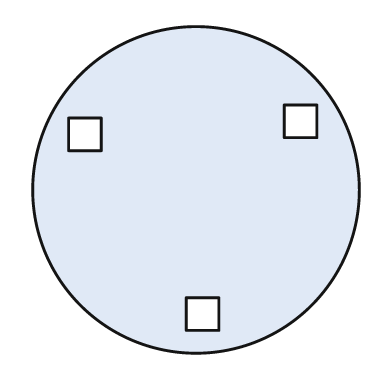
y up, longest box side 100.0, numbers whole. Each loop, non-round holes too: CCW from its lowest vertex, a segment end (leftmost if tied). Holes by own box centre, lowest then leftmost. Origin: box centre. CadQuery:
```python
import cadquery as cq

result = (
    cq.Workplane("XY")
    .moveTo(0.0, 0.0)
    .circle(50.0)
    .moveTo(-3.0, -43.0)
    .lineTo(7.0, -43.0)
    .lineTo(7.0, -33.0)
    .lineTo(-3.0, -33.0)
    .close()
    .moveTo(-39.0, 12.0)
    .lineTo(-29.0, 12.0)
    .lineTo(-29.0, 22.0)
    .lineTo(-39.0, 22.0)
    .close()
    .moveTo(27.0, 16.0)
    .lineTo(37.0, 16.0)
    .lineTo(37.0, 26.0)
    .lineTo(27.0, 26.0)
    .close()
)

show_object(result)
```